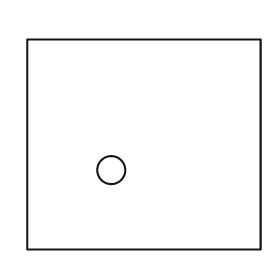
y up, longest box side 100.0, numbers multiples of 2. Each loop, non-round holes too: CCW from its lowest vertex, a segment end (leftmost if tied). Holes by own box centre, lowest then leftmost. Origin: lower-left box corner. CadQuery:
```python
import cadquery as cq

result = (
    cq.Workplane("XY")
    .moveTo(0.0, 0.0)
    .lineTo(100.0, 0.0)
    .lineTo(100.0, 90.0)
    .lineTo(0.0, 90.0)
    .close()
    .moveTo(36.0, 34.0)
    .circle(6.0)
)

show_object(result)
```